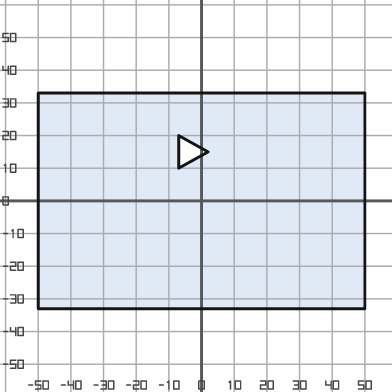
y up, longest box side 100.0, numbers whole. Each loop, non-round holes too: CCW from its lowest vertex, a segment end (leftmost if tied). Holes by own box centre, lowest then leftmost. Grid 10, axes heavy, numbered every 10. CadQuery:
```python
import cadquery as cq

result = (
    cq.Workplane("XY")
    .moveTo(-50.0, -33.0)
    .lineTo(50.0, -33.0)
    .lineTo(50.0, 33.0)
    .lineTo(-50.0, 33.0)
    .close()
    .moveTo(-7.0, 10.0)
    .lineTo(2.0, 15.0)
    .lineTo(-7.0, 20.0)
    .close()
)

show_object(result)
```